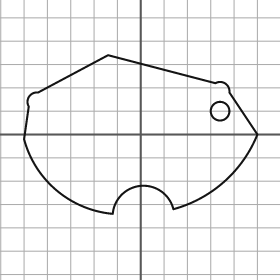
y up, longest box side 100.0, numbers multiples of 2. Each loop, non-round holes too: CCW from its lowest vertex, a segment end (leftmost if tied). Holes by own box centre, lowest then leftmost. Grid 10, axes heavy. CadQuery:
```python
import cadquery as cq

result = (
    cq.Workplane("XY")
    .moveTo(-12.0, -34.0)
    .threePointArc((0.0, -22.0), (14.0, -32.0))
    .threePointArc((36.0, -20.0), (50.0, 0.0))
    .lineTo(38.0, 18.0)
    .threePointArc((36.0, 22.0), (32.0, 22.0))
    .lineTo(-14.0, 34.0)
    .lineTo(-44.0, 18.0)
    .threePointArc((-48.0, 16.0), (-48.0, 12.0))
    .lineTo(-50.0, -2.0)
    .threePointArc((-36.0, -24.0), (-12.0, -34.0))
    .close()
    .moveTo(34.0, 10.0)
    .circle(4.0)
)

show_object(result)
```